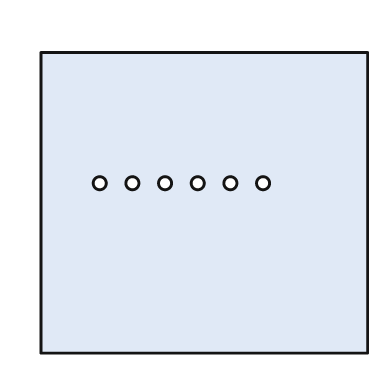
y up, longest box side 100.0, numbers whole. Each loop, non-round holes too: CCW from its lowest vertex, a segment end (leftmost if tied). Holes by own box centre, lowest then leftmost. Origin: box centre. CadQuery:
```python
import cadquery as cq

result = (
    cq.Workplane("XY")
    .moveTo(-50.0, -46.0)
    .lineTo(50.0, -46.0)
    .lineTo(50.0, 46.0)
    .lineTo(-50.0, 46.0)
    .close()
    .moveTo(-32.0, 6.0)
    .circle(2.0)
    .moveTo(-22.0, 6.0)
    .circle(2.0)
    .moveTo(-12.0, 6.0)
    .circle(2.0)
    .moveTo(-2.0, 6.0)
    .circle(2.0)
    .moveTo(8.0, 6.0)
    .circle(2.0)
    .moveTo(18.0, 6.0)
    .circle(2.0)
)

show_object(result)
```